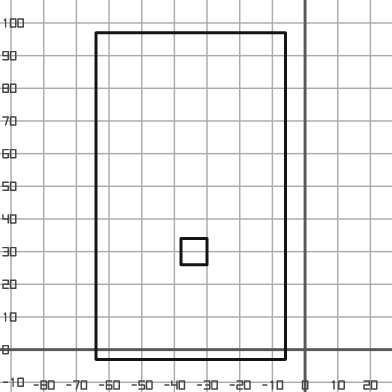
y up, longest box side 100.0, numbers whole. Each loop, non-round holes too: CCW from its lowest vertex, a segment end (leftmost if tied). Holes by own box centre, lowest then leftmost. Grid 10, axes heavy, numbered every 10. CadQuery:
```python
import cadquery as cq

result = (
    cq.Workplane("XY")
    .moveTo(-64.0, -3.0)
    .lineTo(-6.0, -3.0)
    .lineTo(-6.0, 97.0)
    .lineTo(-64.0, 97.0)
    .close()
    .moveTo(-38.0, 26.0)
    .lineTo(-30.0, 26.0)
    .lineTo(-30.0, 34.0)
    .lineTo(-38.0, 34.0)
    .close()
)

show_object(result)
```